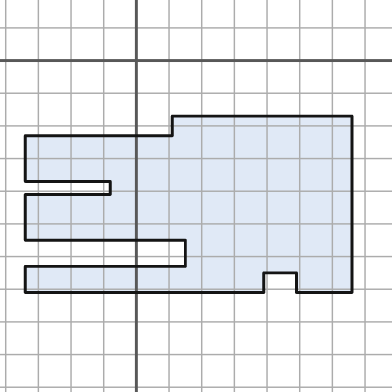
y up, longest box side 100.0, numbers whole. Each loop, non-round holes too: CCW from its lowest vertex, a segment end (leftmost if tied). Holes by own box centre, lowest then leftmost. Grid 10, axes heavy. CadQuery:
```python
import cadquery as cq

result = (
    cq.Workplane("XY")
    .moveTo(-34.0, -71.0)
    .lineTo(39.0, -71.0)
    .lineTo(39.0, -65.0)
    .lineTo(49.0, -65.0)
    .lineTo(49.0, -71.0)
    .lineTo(66.0, -71.0)
    .lineTo(66.0, -17.0)
    .lineTo(11.0, -17.0)
    .lineTo(11.0, -23.0)
    .lineTo(-34.0, -23.0)
    .lineTo(-34.0, -37.0)
    .lineTo(-8.0, -37.0)
    .lineTo(-8.0, -41.0)
    .lineTo(-34.0, -41.0)
    .lineTo(-34.0, -55.0)
    .lineTo(15.0, -55.0)
    .lineTo(15.0, -63.0)
    .lineTo(-34.0, -63.0)
    .close()
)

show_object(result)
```